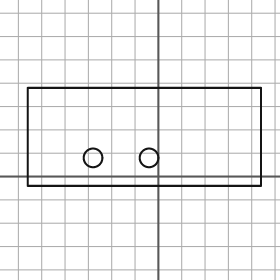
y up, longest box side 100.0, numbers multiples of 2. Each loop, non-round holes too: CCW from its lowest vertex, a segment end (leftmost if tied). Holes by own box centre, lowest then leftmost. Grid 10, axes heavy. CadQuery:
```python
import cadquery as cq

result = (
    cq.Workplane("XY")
    .moveTo(-56.0, -4.0)
    .lineTo(44.0, -4.0)
    .lineTo(44.0, 38.0)
    .lineTo(-56.0, 38.0)
    .close()
    .moveTo(-28.0, 8.0)
    .circle(4.0)
    .moveTo(-4.0, 8.0)
    .circle(4.0)
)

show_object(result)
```